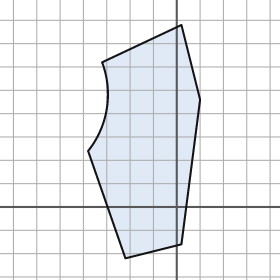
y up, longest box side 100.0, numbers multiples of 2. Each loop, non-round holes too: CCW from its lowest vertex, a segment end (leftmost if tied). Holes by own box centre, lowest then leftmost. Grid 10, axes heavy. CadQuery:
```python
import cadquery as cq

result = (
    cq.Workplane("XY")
    .moveTo(-22.0, -22.0)
    .lineTo(2.0, -16.0)
    .lineTo(10.0, 46.0)
    .lineTo(2.0, 78.0)
    .lineTo(-32.0, 62.0)
    .threePointArc((-30.0, 42.0), (-38.0, 24.0))
    .close()
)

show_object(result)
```